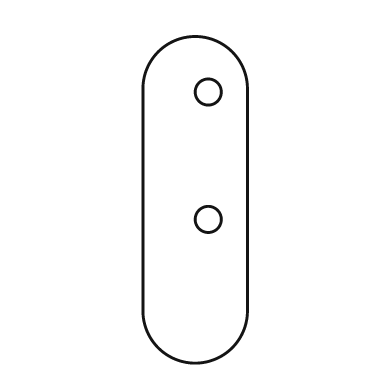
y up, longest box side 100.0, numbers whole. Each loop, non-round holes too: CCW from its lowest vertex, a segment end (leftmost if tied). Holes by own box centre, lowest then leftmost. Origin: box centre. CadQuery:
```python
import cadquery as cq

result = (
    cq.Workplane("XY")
    .moveTo(-16.0, -34.0)
    .threePointArc((0.0, -50.0), (16.0, -34.0))
    .lineTo(16.0, 34.0)
    .threePointArc((0.0, 50.0), (-16.0, 34.0))
    .close()
    .moveTo(4.0, -6.0)
    .circle(4.0)
    .moveTo(4.0, 33.0)
    .circle(4.0)
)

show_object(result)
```